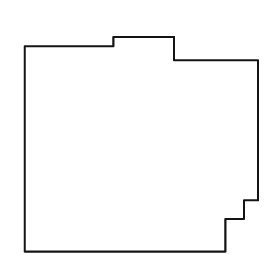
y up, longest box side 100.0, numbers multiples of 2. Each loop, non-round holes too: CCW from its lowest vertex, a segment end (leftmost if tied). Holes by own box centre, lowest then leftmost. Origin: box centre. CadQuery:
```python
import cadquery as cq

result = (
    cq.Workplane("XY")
    .moveTo(-50.0, -46.0)
    .lineTo(36.0, -46.0)
    .lineTo(36.0, -32.0)
    .lineTo(44.0, -32.0)
    .lineTo(44.0, -24.0)
    .lineTo(50.0, -24.0)
    .lineTo(50.0, 36.0)
    .lineTo(14.0, 36.0)
    .lineTo(14.0, 46.0)
    .lineTo(-12.0, 46.0)
    .lineTo(-12.0, 42.0)
    .lineTo(-50.0, 42.0)
    .close()
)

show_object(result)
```